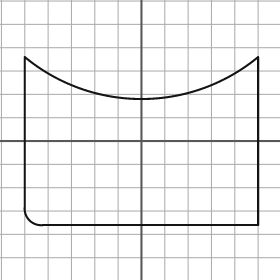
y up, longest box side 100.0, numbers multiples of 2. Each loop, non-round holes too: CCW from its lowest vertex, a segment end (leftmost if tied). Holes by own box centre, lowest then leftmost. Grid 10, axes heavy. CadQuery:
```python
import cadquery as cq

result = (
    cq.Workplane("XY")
    .moveTo(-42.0, -36.0)
    .lineTo(50.0, -36.0)
    .lineTo(50.0, 36.0)
    .threePointArc((0.0, 18.0), (-50.0, 36.0))
    .lineTo(-50.0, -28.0)
    .threePointArc((-48.0, -34.0), (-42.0, -36.0))
    .close()
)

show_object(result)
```